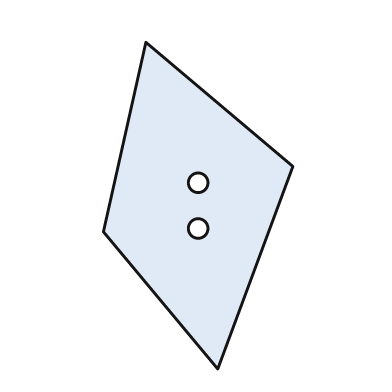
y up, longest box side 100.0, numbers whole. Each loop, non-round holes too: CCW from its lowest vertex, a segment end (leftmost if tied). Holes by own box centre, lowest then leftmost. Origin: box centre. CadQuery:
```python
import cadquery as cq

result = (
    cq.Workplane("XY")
    .moveTo(6.0, -50.0)
    .lineTo(29.0, 12.0)
    .lineTo(-16.0, 50.0)
    .lineTo(-29.0, -8.0)
    .close()
    .moveTo(0.0, -7.0)
    .circle(3.0)
    .moveTo(0.0, 7.0)
    .circle(3.0)
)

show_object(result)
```